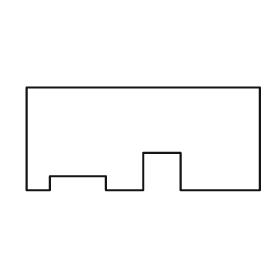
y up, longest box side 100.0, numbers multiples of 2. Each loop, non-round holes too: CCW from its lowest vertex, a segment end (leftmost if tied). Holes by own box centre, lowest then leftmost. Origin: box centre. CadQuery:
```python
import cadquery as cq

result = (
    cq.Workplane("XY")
    .moveTo(-50.0, -22.0)
    .lineTo(-40.0, -22.0)
    .lineTo(-40.0, -16.0)
    .lineTo(-16.0, -16.0)
    .lineTo(-16.0, -22.0)
    .lineTo(0.0, -22.0)
    .lineTo(0.0, -6.0)
    .lineTo(16.0, -6.0)
    .lineTo(16.0, -22.0)
    .lineTo(50.0, -22.0)
    .lineTo(50.0, 22.0)
    .lineTo(-50.0, 22.0)
    .close()
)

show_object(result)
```